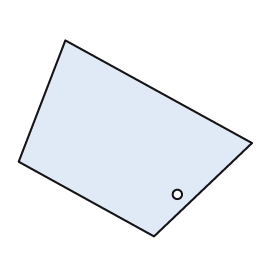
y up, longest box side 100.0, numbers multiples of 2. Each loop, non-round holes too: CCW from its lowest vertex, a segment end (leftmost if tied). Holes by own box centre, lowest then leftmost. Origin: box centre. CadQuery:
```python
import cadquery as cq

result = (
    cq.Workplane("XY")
    .moveTo(8.0, -42.0)
    .lineTo(50.0, -2.0)
    .lineTo(-30.0, 42.0)
    .lineTo(-50.0, -10.0)
    .close()
    .moveTo(18.0, -24.0)
    .circle(2.0)
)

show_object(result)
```